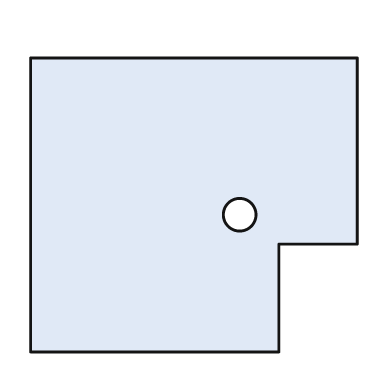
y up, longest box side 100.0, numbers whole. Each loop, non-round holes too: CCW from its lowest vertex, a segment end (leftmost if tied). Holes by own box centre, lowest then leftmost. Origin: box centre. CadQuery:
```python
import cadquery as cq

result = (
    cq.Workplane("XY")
    .moveTo(-50.0, -45.0)
    .lineTo(26.0, -45.0)
    .lineTo(26.0, -12.0)
    .lineTo(50.0, -12.0)
    .lineTo(50.0, 45.0)
    .lineTo(-50.0, 45.0)
    .close()
    .moveTo(14.0, -3.0)
    .circle(5.0)
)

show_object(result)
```